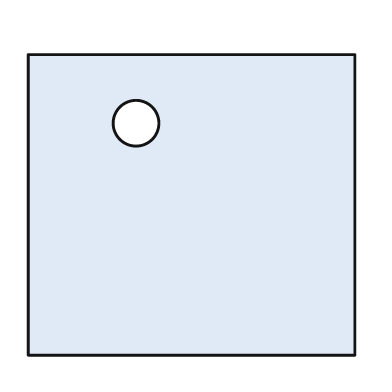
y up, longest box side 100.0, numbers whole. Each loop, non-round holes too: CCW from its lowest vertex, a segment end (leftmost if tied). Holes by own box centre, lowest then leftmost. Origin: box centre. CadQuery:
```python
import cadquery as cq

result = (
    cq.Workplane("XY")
    .moveTo(-50.0, -46.0)
    .lineTo(50.0, -46.0)
    .lineTo(50.0, 46.0)
    .lineTo(-50.0, 46.0)
    .close()
    .moveTo(-17.0, 25.0)
    .circle(7.0)
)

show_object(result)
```